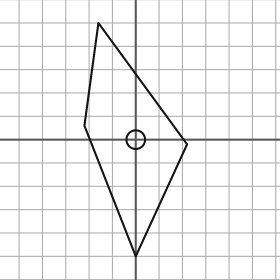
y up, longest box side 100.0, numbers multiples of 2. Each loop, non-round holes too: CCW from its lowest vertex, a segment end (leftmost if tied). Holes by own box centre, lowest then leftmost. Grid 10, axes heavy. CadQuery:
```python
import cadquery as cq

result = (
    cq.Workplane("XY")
    .moveTo(0.0, -50.0)
    .lineTo(22.0, -2.0)
    .lineTo(-16.0, 50.0)
    .lineTo(-22.0, 6.0)
    .close()
    .moveTo(0.0, 0.0)
    .circle(4.0)
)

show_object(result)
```